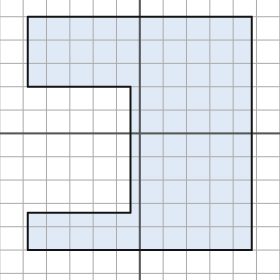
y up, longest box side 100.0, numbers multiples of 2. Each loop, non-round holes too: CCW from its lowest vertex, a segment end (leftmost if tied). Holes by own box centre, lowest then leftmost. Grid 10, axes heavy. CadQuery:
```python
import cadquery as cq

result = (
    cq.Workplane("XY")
    .moveTo(-48.0, -50.0)
    .lineTo(48.0, -50.0)
    .lineTo(48.0, 50.0)
    .lineTo(-48.0, 50.0)
    .lineTo(-48.0, 20.0)
    .lineTo(-4.0, 20.0)
    .lineTo(-4.0, -34.0)
    .lineTo(-48.0, -34.0)
    .close()
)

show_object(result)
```